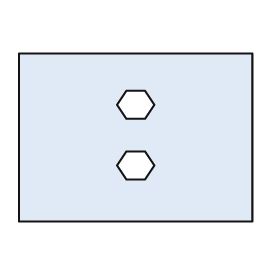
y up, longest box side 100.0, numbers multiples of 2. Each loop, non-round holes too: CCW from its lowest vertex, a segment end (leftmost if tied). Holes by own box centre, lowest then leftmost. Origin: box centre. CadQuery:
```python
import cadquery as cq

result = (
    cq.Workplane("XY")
    .moveTo(-50.0, -36.0)
    .lineTo(50.0, -36.0)
    .lineTo(50.0, 36.0)
    .lineTo(-50.0, 36.0)
    .close()
    .moveTo(-4.0, -18.0)
    .lineTo(4.0, -18.0)
    .lineTo(8.0, -12.0)
    .lineTo(4.0, -6.0)
    .lineTo(-4.0, -6.0)
    .lineTo(-8.0, -12.0)
    .close()
    .moveTo(-4.0, 8.0)
    .lineTo(4.0, 8.0)
    .lineTo(8.0, 14.0)
    .lineTo(4.0, 20.0)
    .lineTo(-4.0, 20.0)
    .lineTo(-8.0, 14.0)
    .close()
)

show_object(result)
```